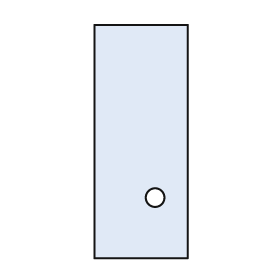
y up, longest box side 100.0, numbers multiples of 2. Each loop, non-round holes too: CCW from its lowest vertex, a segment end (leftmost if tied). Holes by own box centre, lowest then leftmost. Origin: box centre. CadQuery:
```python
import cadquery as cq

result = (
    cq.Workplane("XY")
    .moveTo(-20.0, -50.0)
    .lineTo(20.0, -50.0)
    .lineTo(20.0, 50.0)
    .lineTo(-20.0, 50.0)
    .close()
    .moveTo(6.0, -24.0)
    .circle(4.0)
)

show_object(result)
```